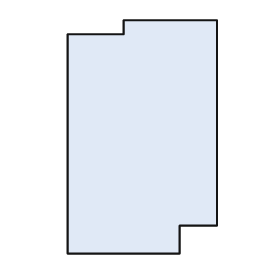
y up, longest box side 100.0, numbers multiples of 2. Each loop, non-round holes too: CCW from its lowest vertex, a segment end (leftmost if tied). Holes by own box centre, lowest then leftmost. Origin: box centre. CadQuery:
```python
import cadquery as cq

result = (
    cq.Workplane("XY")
    .moveTo(-32.0, -50.0)
    .lineTo(16.0, -50.0)
    .lineTo(16.0, -38.0)
    .lineTo(32.0, -38.0)
    .lineTo(32.0, 50.0)
    .lineTo(-8.0, 50.0)
    .lineTo(-8.0, 44.0)
    .lineTo(-32.0, 44.0)
    .close()
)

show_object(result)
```